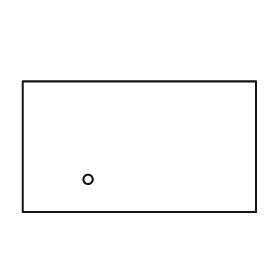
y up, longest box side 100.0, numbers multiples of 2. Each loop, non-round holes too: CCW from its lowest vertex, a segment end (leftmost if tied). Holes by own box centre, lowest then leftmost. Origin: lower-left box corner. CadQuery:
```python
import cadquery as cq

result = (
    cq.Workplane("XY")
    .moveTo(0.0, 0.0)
    .lineTo(100.0, 0.0)
    .lineTo(100.0, 56.0)
    .lineTo(0.0, 56.0)
    .close()
    .moveTo(28.0, 14.0)
    .circle(2.0)
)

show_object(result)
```